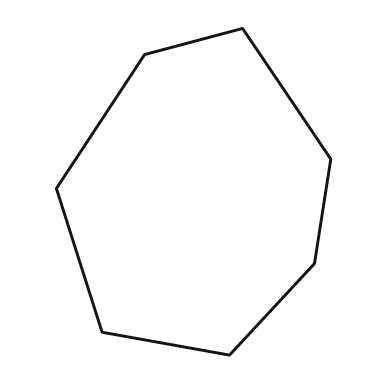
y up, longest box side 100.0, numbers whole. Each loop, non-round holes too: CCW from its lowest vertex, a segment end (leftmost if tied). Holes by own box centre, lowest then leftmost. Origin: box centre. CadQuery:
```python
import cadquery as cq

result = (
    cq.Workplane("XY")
    .moveTo(11.0, -50.0)
    .lineTo(37.0, -22.0)
    .lineTo(42.0, 10.0)
    .lineTo(15.0, 50.0)
    .lineTo(-15.0, 42.0)
    .lineTo(-42.0, 1.0)
    .lineTo(-28.0, -43.0)
    .close()
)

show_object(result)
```